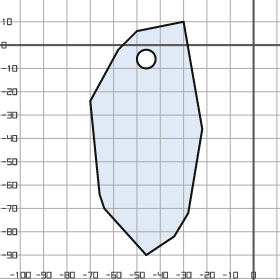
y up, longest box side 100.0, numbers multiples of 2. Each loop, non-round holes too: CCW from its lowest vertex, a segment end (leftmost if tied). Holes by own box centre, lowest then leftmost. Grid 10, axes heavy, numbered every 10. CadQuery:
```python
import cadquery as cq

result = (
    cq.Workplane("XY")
    .moveTo(-46.0, -90.0)
    .lineTo(-34.0, -82.0)
    .lineTo(-28.0, -72.0)
    .lineTo(-22.0, -36.0)
    .lineTo(-30.0, 10.0)
    .lineTo(-50.0, 6.0)
    .lineTo(-58.0, -2.0)
    .lineTo(-70.0, -24.0)
    .lineTo(-66.0, -64.0)
    .lineTo(-64.0, -70.0)
    .close()
    .moveTo(-46.0, -6.0)
    .circle(4.0)
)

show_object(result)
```